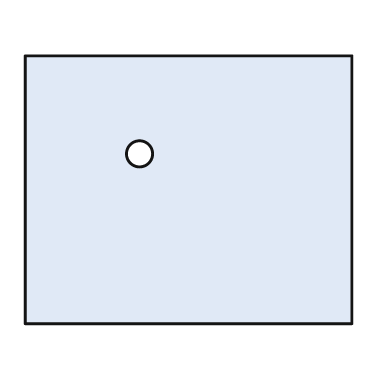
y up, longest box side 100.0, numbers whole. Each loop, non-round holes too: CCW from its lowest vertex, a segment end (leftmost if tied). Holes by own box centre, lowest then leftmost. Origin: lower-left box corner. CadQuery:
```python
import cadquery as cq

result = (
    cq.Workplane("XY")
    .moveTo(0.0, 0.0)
    .lineTo(100.0, 0.0)
    .lineTo(100.0, 82.0)
    .lineTo(0.0, 82.0)
    .close()
    .moveTo(35.0, 52.0)
    .circle(4.0)
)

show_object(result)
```